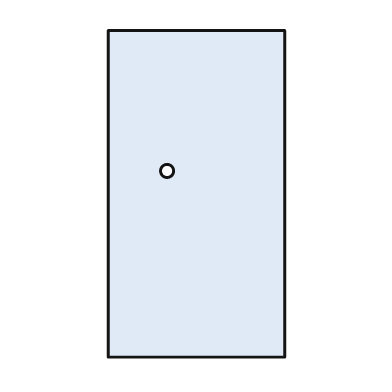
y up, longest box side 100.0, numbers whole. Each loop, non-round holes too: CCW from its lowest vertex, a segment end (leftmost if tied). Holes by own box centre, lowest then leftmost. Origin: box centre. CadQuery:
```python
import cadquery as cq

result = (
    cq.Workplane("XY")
    .moveTo(-27.0, -50.0)
    .lineTo(27.0, -50.0)
    .lineTo(27.0, 50.0)
    .lineTo(-27.0, 50.0)
    .close()
    .moveTo(-9.0, 7.0)
    .circle(2.0)
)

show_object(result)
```